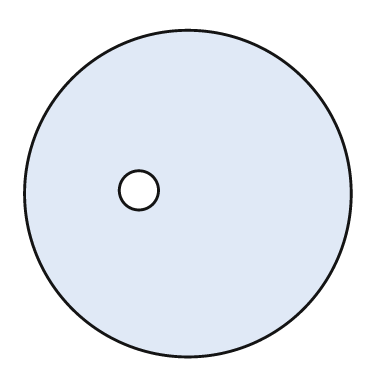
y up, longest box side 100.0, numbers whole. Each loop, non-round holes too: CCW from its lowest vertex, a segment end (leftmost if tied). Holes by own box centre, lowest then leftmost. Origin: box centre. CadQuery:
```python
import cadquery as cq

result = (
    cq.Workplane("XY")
    .moveTo(0.0, 0.0)
    .circle(50.0)
    .moveTo(-15.0, 1.0)
    .circle(6.0)
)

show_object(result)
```